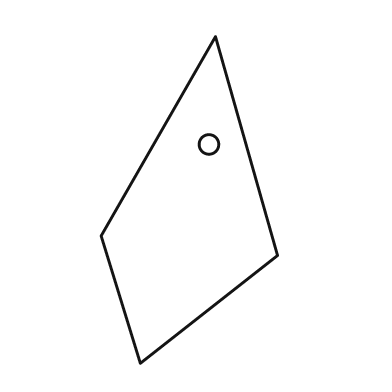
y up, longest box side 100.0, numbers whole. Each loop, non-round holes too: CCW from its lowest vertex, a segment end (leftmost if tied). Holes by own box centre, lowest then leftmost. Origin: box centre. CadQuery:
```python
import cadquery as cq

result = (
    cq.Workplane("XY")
    .moveTo(-15.0, -50.0)
    .lineTo(27.0, -17.0)
    .lineTo(8.0, 50.0)
    .lineTo(-27.0, -11.0)
    .close()
    .moveTo(6.0, 17.0)
    .circle(3.0)
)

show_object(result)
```